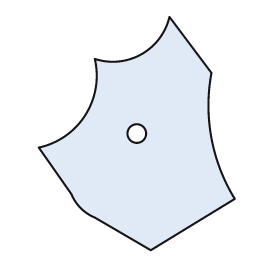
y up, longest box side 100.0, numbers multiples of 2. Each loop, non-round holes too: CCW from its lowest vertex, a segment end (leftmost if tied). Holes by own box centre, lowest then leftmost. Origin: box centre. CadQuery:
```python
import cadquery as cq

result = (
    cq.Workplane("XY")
    .moveTo(6.0, -50.0)
    .lineTo(42.0, -28.0)
    .threePointArc((32.0, -2.0), (32.0, 26.0))
    .lineTo(14.0, 50.0)
    .threePointArc((2.0, 34.0), (-18.0, 32.0))
    .threePointArc((-22.0, 8.0), (-42.0, -6.0))
    .lineTo(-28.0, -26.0)
    .threePointArc((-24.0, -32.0), (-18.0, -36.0))
    .close()
    .moveTo(0.0, 0.0)
    .circle(4.0)
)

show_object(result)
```